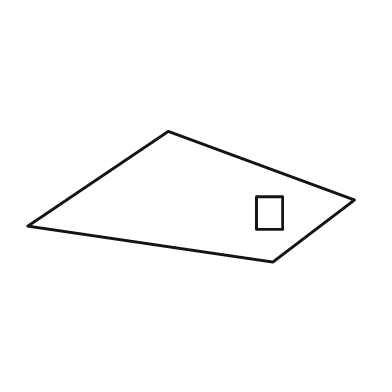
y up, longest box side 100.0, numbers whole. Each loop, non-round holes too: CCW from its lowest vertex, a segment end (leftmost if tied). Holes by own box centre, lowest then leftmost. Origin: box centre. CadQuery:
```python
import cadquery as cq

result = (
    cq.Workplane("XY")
    .moveTo(25.0, -20.0)
    .lineTo(50.0, -1.0)
    .lineTo(-7.0, 20.0)
    .lineTo(-50.0, -9.0)
    .close()
    .moveTo(20.0, -10.0)
    .lineTo(28.0, -10.0)
    .lineTo(28.0, 0.0)
    .lineTo(20.0, 0.0)
    .close()
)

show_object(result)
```